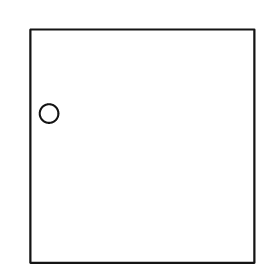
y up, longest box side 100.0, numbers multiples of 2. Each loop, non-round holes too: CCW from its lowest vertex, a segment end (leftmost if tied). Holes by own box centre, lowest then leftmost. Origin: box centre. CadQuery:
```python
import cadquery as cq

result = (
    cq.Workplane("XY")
    .moveTo(-48.0, -50.0)
    .lineTo(48.0, -50.0)
    .lineTo(48.0, 50.0)
    .lineTo(-48.0, 50.0)
    .close()
    .moveTo(-40.0, 14.0)
    .circle(4.0)
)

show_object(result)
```